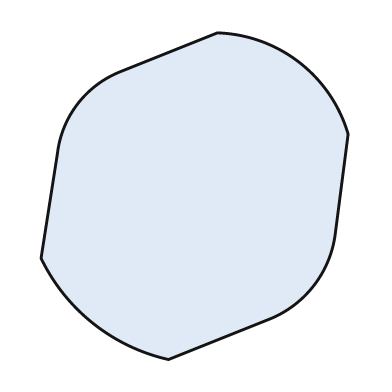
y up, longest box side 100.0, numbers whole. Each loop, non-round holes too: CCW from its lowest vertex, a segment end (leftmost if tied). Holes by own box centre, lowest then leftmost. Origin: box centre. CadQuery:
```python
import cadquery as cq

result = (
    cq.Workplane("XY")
    .moveTo(-8.0, -50.0)
    .lineTo(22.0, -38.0)
    .threePointArc((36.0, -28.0), (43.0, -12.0))
    .lineTo(47.0, 19.0)
    .threePointArc((32.0, 41.0), (7.0, 50.0))
    .lineTo(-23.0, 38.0)
    .threePointArc((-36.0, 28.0), (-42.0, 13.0))
    .lineTo(-47.0, -19.0)
    .threePointArc((-31.0, -39.0), (-8.0, -50.0))
    .close()
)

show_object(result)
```